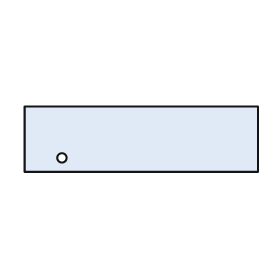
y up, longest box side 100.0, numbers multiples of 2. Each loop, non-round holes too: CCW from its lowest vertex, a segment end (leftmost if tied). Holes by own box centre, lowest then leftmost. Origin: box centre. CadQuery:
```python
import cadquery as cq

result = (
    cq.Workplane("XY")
    .moveTo(-50.0, -14.0)
    .lineTo(50.0, -14.0)
    .lineTo(50.0, 14.0)
    .lineTo(-50.0, 14.0)
    .close()
    .moveTo(-34.0, -8.0)
    .circle(2.0)
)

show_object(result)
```